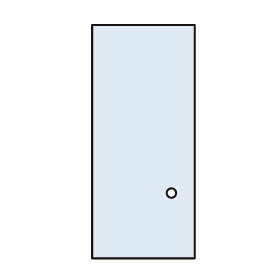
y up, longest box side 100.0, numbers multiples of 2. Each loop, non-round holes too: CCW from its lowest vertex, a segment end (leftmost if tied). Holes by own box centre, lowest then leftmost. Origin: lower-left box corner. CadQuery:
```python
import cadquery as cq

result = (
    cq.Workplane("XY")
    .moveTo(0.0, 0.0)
    .lineTo(44.0, 0.0)
    .lineTo(44.0, 100.0)
    .lineTo(0.0, 100.0)
    .close()
    .moveTo(34.0, 28.0)
    .circle(2.0)
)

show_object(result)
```